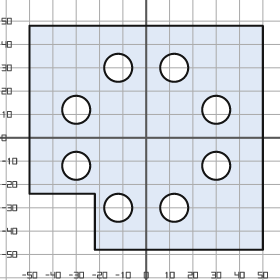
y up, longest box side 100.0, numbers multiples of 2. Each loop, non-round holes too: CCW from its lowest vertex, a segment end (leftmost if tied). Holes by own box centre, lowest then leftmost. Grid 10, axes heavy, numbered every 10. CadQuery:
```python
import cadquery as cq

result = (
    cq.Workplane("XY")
    .moveTo(-22.0, -48.0)
    .lineTo(50.0, -48.0)
    .lineTo(50.0, 48.0)
    .lineTo(-50.0, 48.0)
    .lineTo(-50.0, -24.0)
    .lineTo(-22.0, -24.0)
    .close()
    .moveTo(-12.0, -30.0)
    .circle(6.0)
    .moveTo(12.0, -30.0)
    .circle(6.0)
    .moveTo(-30.0, -12.0)
    .circle(6.0)
    .moveTo(30.0, -12.0)
    .circle(6.0)
    .moveTo(-30.0, 12.0)
    .circle(6.0)
    .moveTo(30.0, 12.0)
    .circle(6.0)
    .moveTo(-12.0, 30.0)
    .circle(6.0)
    .moveTo(12.0, 30.0)
    .circle(6.0)
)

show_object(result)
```